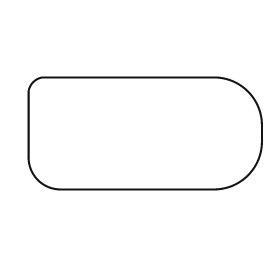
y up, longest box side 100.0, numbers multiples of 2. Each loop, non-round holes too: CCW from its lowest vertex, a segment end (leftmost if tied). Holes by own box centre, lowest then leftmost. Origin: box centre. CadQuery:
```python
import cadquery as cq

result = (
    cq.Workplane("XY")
    .moveTo(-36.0, -24.0)
    .lineTo(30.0, -24.0)
    .threePointArc((44.0, -18.0), (50.0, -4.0))
    .lineTo(50.0, 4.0)
    .threePointArc((44.0, 18.0), (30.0, 24.0))
    .lineTo(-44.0, 24.0)
    .threePointArc((-48.0, 22.0), (-50.0, 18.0))
    .lineTo(-50.0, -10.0)
    .threePointArc((-46.0, -20.0), (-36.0, -24.0))
    .close()
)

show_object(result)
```